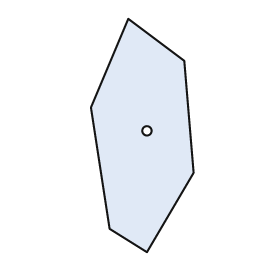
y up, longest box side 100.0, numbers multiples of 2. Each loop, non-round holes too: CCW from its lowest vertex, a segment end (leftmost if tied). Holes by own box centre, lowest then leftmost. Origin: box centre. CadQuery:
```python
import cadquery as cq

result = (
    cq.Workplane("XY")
    .moveTo(2.0, -50.0)
    .lineTo(22.0, -16.0)
    .lineTo(18.0, 32.0)
    .lineTo(-6.0, 50.0)
    .lineTo(-22.0, 12.0)
    .lineTo(-14.0, -40.0)
    .close()
    .moveTo(2.0, 2.0)
    .circle(2.0)
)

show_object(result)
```